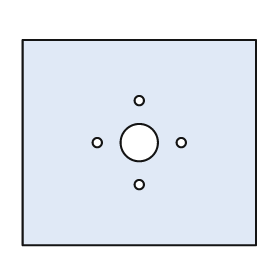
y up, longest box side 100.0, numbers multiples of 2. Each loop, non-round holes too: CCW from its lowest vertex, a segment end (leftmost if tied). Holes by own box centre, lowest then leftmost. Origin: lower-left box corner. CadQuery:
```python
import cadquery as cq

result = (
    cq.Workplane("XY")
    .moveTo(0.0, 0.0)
    .lineTo(100.0, 0.0)
    .lineTo(100.0, 88.0)
    .lineTo(0.0, 88.0)
    .close()
    .moveTo(50.0, 26.0)
    .circle(2.0)
    .moveTo(32.0, 44.0)
    .circle(2.0)
    .moveTo(50.0, 44.0)
    .circle(8.0)
    .moveTo(68.0, 44.0)
    .circle(2.0)
    .moveTo(50.0, 62.0)
    .circle(2.0)
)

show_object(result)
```